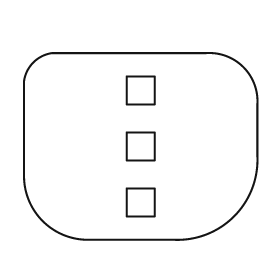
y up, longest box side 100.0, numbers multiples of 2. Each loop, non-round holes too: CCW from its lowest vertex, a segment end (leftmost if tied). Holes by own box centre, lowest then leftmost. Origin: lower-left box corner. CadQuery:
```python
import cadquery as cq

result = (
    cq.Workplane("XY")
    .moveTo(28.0, 0.0)
    .lineTo(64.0, 0.0)
    .threePointArc((90.0, 10.0), (100.0, 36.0))
    .lineTo(100.0, 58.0)
    .threePointArc((94.0, 74.0), (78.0, 80.0))
    .lineTo(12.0, 80.0)
    .threePointArc((4.0, 76.0), (0.0, 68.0))
    .lineTo(0.0, 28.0)
    .threePointArc((8.0, 8.0), (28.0, 0.0))
    .close()
    .moveTo(44.0, 10.0)
    .lineTo(56.0, 10.0)
    .lineTo(56.0, 22.0)
    .lineTo(44.0, 22.0)
    .close()
    .moveTo(44.0, 34.0)
    .lineTo(56.0, 34.0)
    .lineTo(56.0, 46.0)
    .lineTo(44.0, 46.0)
    .close()
    .moveTo(44.0, 58.0)
    .lineTo(56.0, 58.0)
    .lineTo(56.0, 70.0)
    .lineTo(44.0, 70.0)
    .close()
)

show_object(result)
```